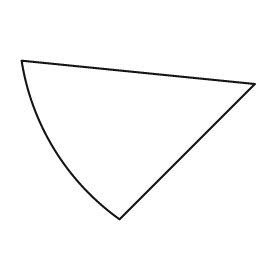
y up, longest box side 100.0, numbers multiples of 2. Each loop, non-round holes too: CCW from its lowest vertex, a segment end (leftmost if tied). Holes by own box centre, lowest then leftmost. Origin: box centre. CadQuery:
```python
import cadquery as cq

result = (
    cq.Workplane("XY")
    .moveTo(-8.0, -34.0)
    .lineTo(50.0, 24.0)
    .lineTo(-50.0, 34.0)
    .threePointArc((-36.0, -4.0), (-8.0, -34.0))
    .close()
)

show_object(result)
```